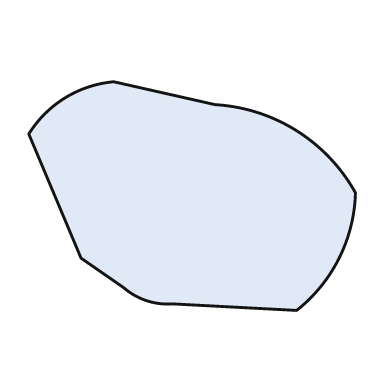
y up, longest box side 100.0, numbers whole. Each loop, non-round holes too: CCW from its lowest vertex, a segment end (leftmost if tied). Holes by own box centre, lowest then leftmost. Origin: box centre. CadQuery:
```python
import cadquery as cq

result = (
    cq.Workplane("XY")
    .moveTo(32.0, -35.0)
    .threePointArc((45.0, -19.0), (50.0, 1.0))
    .threePointArc((32.0, 20.0), (7.0, 28.0))
    .lineTo(-24.0, 35.0)
    .threePointArc((-39.0, 30.0), (-50.0, 19.0))
    .lineTo(-34.0, -19.0)
    .lineTo(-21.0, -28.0)
    .threePointArc((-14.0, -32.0), (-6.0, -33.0))
    .close()
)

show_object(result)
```